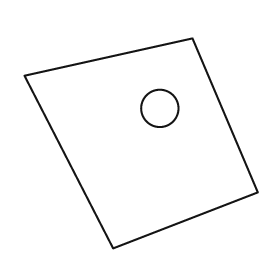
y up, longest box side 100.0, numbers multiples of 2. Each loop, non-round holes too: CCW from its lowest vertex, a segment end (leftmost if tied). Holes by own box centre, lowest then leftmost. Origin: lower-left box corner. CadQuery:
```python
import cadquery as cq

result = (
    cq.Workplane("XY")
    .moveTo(38.0, 0.0)
    .lineTo(100.0, 24.0)
    .lineTo(72.0, 90.0)
    .lineTo(0.0, 74.0)
    .close()
    .moveTo(58.0, 60.0)
    .circle(8.0)
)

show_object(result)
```